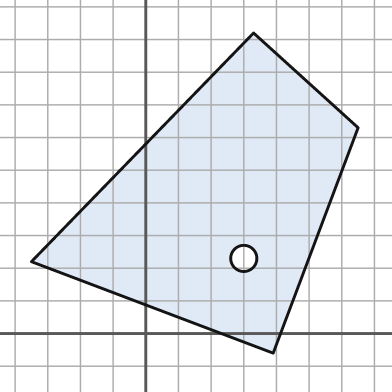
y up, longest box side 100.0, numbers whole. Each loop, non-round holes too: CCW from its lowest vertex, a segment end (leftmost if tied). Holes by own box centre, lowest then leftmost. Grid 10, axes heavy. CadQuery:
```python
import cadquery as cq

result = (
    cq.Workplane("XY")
    .moveTo(39.0, -6.0)
    .lineTo(65.0, 63.0)
    .lineTo(33.0, 92.0)
    .lineTo(-35.0, 22.0)
    .close()
    .moveTo(30.0, 23.0)
    .circle(4.0)
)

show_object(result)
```